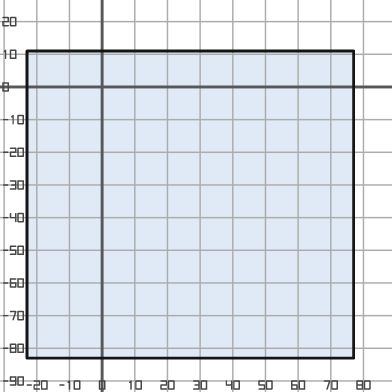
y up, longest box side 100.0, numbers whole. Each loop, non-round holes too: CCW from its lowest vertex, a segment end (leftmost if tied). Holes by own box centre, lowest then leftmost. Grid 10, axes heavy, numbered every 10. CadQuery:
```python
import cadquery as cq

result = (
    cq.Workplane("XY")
    .moveTo(-23.0, -83.0)
    .lineTo(77.0, -83.0)
    .lineTo(77.0, 11.0)
    .lineTo(-23.0, 11.0)
    .close()
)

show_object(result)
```